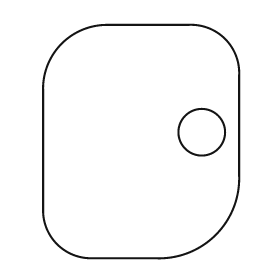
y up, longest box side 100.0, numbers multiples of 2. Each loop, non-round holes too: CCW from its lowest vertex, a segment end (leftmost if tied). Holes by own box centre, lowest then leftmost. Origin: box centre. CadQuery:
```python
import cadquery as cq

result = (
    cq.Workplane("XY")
    .moveTo(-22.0, -50.0)
    .lineTo(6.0, -50.0)
    .threePointArc((32.0, -40.0), (42.0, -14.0))
    .lineTo(42.0, 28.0)
    .threePointArc((36.0, 44.0), (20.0, 50.0))
    .lineTo(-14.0, 50.0)
    .threePointArc((-34.0, 42.0), (-42.0, 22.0))
    .lineTo(-42.0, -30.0)
    .threePointArc((-36.0, -44.0), (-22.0, -50.0))
    .close()
    .moveTo(26.0, 4.0)
    .circle(10.0)
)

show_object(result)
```